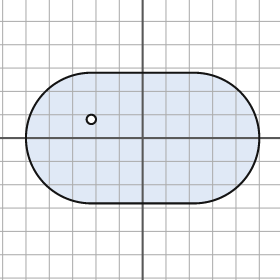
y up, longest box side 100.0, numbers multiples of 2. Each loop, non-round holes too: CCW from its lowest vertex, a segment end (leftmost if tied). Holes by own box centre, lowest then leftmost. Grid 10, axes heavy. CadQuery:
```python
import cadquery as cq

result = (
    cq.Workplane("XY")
    .moveTo(-22.0, -28.0)
    .lineTo(22.0, -28.0)
    .threePointArc((50.0, 0.0), (22.0, 28.0))
    .lineTo(-22.0, 28.0)
    .threePointArc((-50.0, 0.0), (-22.0, -28.0))
    .close()
    .moveTo(-22.0, 8.0)
    .circle(2.0)
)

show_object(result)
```